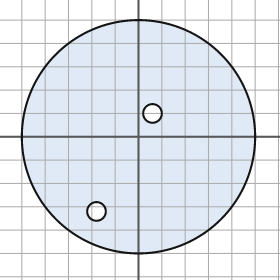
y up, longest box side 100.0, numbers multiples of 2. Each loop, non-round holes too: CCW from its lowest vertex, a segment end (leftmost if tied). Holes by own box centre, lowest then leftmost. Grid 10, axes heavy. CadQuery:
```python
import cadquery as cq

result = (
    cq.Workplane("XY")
    .moveTo(0.0, 0.0)
    .circle(50.0)
    .moveTo(-18.0, -32.0)
    .circle(4.0)
    .moveTo(6.0, 10.0)
    .circle(4.0)
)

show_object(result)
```